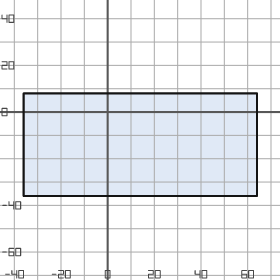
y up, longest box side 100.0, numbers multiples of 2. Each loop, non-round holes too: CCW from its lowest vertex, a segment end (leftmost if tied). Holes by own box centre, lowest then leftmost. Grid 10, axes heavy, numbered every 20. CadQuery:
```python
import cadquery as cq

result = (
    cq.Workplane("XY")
    .moveTo(-36.0, -36.0)
    .lineTo(64.0, -36.0)
    .lineTo(64.0, 8.0)
    .lineTo(-36.0, 8.0)
    .close()
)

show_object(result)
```